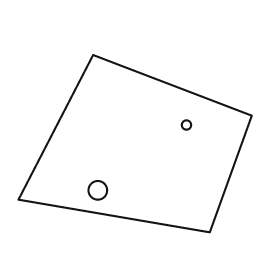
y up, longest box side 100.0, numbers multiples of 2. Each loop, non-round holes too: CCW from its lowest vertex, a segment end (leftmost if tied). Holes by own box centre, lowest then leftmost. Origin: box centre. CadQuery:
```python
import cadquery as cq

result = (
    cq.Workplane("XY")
    .moveTo(32.0, -38.0)
    .lineTo(50.0, 12.0)
    .lineTo(-18.0, 38.0)
    .lineTo(-50.0, -24.0)
    .close()
    .moveTo(-16.0, -20.0)
    .circle(4.0)
    .moveTo(22.0, 8.0)
    .circle(2.0)
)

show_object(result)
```